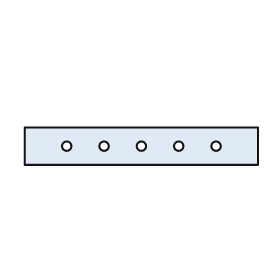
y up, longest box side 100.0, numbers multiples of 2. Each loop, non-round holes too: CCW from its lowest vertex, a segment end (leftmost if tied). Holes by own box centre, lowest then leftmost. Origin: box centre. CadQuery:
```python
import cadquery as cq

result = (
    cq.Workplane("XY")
    .moveTo(-50.0, -8.0)
    .lineTo(50.0, -8.0)
    .lineTo(50.0, 8.0)
    .lineTo(-50.0, 8.0)
    .close()
    .moveTo(-32.0, 0.0)
    .circle(2.0)
    .moveTo(-16.0, 0.0)
    .circle(2.0)
    .moveTo(0.0, 0.0)
    .circle(2.0)
    .moveTo(16.0, 0.0)
    .circle(2.0)
    .moveTo(32.0, 0.0)
    .circle(2.0)
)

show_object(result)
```